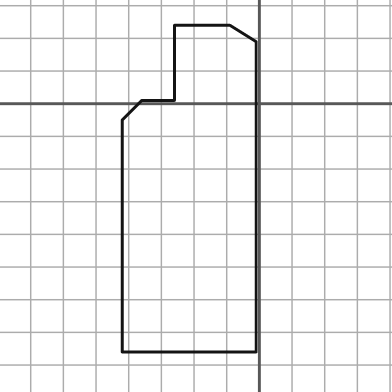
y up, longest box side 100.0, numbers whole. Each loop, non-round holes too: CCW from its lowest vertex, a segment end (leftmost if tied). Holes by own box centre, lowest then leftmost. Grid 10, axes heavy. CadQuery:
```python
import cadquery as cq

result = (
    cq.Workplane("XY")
    .moveTo(-42.0, -76.0)
    .lineTo(-1.0, -76.0)
    .lineTo(-1.0, 19.0)
    .lineTo(-9.0, 24.0)
    .lineTo(-26.0, 24.0)
    .lineTo(-26.0, 1.0)
    .lineTo(-36.0, 1.0)
    .lineTo(-42.0, -5.0)
    .close()
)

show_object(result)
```